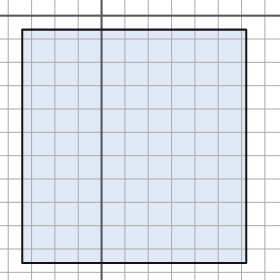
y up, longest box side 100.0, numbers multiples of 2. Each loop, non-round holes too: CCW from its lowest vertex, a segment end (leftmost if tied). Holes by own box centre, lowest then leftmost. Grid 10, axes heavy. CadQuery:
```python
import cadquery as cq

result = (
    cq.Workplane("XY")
    .moveTo(-34.0, -106.0)
    .lineTo(62.0, -106.0)
    .lineTo(62.0, -6.0)
    .lineTo(-34.0, -6.0)
    .close()
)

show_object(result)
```